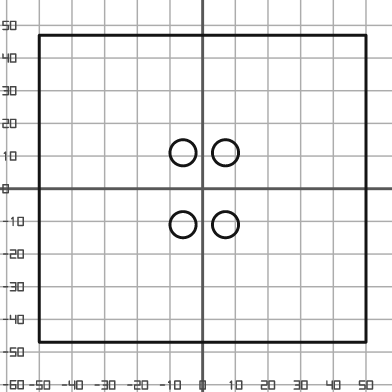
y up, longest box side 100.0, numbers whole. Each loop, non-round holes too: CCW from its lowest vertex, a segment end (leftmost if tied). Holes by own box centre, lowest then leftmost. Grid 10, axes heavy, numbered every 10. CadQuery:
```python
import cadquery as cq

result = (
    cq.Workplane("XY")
    .moveTo(-50.0, -47.0)
    .lineTo(50.0, -47.0)
    .lineTo(50.0, 47.0)
    .lineTo(-50.0, 47.0)
    .close()
    .moveTo(-6.0, -11.0)
    .circle(4.0)
    .moveTo(7.0, -11.0)
    .circle(4.0)
    .moveTo(-6.0, 11.0)
    .circle(4.0)
    .moveTo(7.0, 11.0)
    .circle(4.0)
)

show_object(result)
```